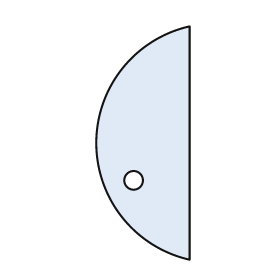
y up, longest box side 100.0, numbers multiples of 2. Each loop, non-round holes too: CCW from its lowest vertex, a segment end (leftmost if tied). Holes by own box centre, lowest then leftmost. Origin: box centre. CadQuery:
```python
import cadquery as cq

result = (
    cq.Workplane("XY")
    .moveTo(20.0, -50.0)
    .lineTo(20.0, 50.0)
    .threePointArc((-20.0, 0.0), (20.0, -50.0))
    .close()
    .moveTo(-4.0, -16.0)
    .circle(4.0)
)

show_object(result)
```